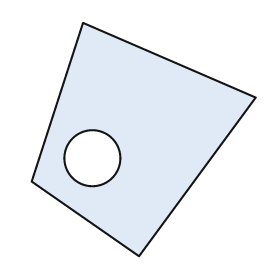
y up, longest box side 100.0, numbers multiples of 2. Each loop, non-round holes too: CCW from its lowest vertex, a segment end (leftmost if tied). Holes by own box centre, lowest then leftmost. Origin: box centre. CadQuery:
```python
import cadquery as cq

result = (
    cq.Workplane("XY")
    .moveTo(-2.0, -50.0)
    .lineTo(48.0, 18.0)
    .lineTo(-26.0, 50.0)
    .lineTo(-48.0, -18.0)
    .close()
    .moveTo(-22.0, -8.0)
    .circle(12.0)
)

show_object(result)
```